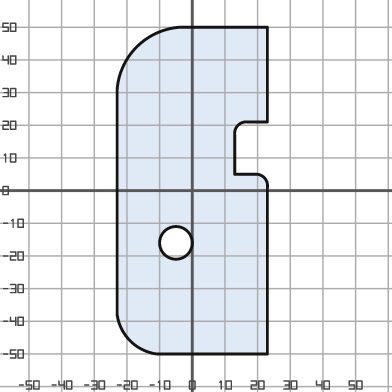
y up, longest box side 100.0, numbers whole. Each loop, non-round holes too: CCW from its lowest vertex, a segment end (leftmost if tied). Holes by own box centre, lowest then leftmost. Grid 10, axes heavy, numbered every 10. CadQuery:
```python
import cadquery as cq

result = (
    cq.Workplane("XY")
    .moveTo(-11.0, -50.0)
    .lineTo(23.0, -50.0)
    .lineTo(23.0, 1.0)
    .threePointArc((22.0, 4.0), (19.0, 5.0))
    .lineTo(13.0, 5.0)
    .lineTo(13.0, 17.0)
    .threePointArc((14.0, 20.0), (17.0, 21.0))
    .lineTo(23.0, 21.0)
    .lineTo(23.0, 50.0)
    .lineTo(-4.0, 50.0)
    .threePointArc((-17.0, 44.0), (-23.0, 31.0))
    .lineTo(-23.0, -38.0)
    .threePointArc((-19.0, -46.0), (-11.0, -50.0))
    .close()
    .moveTo(-5.0, -16.0)
    .circle(5.0)
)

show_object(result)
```